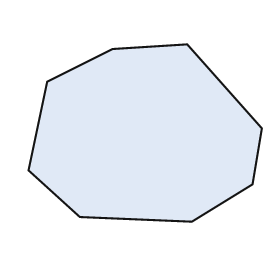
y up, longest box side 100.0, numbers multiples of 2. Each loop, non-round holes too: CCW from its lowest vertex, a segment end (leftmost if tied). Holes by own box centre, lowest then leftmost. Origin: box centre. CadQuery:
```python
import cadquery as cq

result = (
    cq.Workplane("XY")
    .moveTo(20.0, -38.0)
    .lineTo(46.0, -22.0)
    .lineTo(50.0, 2.0)
    .lineTo(18.0, 38.0)
    .lineTo(-14.0, 36.0)
    .lineTo(-42.0, 22.0)
    .lineTo(-50.0, -16.0)
    .lineTo(-28.0, -36.0)
    .close()
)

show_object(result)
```